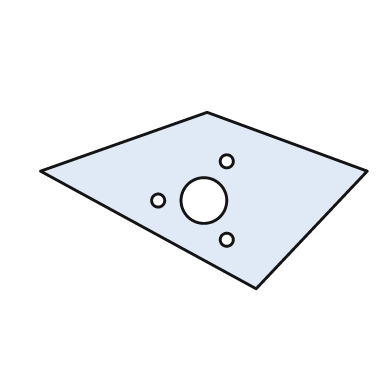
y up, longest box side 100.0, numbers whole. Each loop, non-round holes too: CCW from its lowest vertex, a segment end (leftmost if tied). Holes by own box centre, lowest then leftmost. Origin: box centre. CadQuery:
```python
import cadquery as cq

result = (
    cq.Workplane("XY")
    .moveTo(16.0, -27.0)
    .lineTo(50.0, 9.0)
    .lineTo(1.0, 27.0)
    .lineTo(-50.0, 9.0)
    .close()
    .moveTo(7.0, -12.0)
    .circle(2.0)
    .moveTo(-14.0, 0.0)
    .circle(2.0)
    .moveTo(0.0, 0.0)
    .circle(7.0)
    .moveTo(7.0, 12.0)
    .circle(2.0)
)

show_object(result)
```